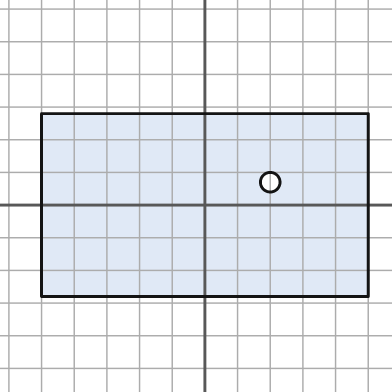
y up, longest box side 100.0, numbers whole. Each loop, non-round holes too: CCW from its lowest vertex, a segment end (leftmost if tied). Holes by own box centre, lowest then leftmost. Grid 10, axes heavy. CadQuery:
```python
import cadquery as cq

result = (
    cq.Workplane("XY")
    .moveTo(-50.0, -28.0)
    .lineTo(50.0, -28.0)
    .lineTo(50.0, 28.0)
    .lineTo(-50.0, 28.0)
    .close()
    .moveTo(20.0, 7.0)
    .circle(3.0)
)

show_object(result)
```